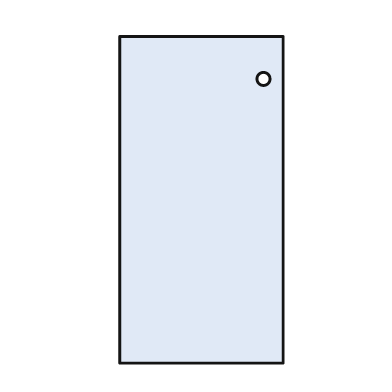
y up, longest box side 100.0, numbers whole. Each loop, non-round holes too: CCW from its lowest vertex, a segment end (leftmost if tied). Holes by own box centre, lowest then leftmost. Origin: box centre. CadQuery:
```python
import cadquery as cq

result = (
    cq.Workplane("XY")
    .moveTo(-25.0, -50.0)
    .lineTo(25.0, -50.0)
    .lineTo(25.0, 50.0)
    .lineTo(-25.0, 50.0)
    .close()
    .moveTo(19.0, 37.0)
    .circle(2.0)
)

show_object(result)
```